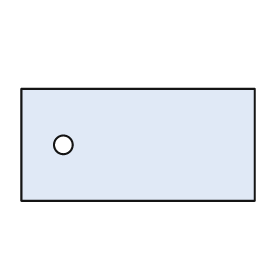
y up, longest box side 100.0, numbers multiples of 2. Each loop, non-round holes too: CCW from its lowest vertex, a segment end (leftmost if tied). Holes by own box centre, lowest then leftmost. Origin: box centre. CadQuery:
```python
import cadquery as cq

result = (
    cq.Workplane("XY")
    .moveTo(-50.0, -24.0)
    .lineTo(50.0, -24.0)
    .lineTo(50.0, 24.0)
    .lineTo(-50.0, 24.0)
    .close()
    .moveTo(-32.0, 0.0)
    .circle(4.0)
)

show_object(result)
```